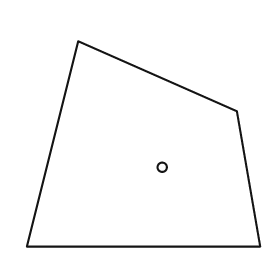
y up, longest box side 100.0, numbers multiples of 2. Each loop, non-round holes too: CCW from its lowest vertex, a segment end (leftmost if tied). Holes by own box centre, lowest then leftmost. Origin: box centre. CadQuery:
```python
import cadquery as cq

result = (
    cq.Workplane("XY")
    .moveTo(-50.0, -44.0)
    .lineTo(50.0, -44.0)
    .lineTo(40.0, 14.0)
    .lineTo(-28.0, 44.0)
    .close()
    .moveTo(8.0, -10.0)
    .circle(2.0)
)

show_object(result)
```